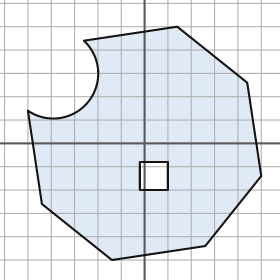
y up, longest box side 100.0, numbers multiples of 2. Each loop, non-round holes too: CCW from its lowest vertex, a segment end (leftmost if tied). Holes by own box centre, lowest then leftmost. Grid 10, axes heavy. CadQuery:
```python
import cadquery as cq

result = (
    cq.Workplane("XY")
    .moveTo(-14.0, -50.0)
    .lineTo(26.0, -44.0)
    .lineTo(50.0, -14.0)
    .lineTo(44.0, 26.0)
    .lineTo(14.0, 50.0)
    .lineTo(-26.0, 44.0)
    .threePointArc((-24.0, 18.0), (-50.0, 14.0))
    .lineTo(-44.0, -26.0)
    .close()
    .moveTo(-2.0, -20.0)
    .lineTo(10.0, -20.0)
    .lineTo(10.0, -8.0)
    .lineTo(-2.0, -8.0)
    .close()
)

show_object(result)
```